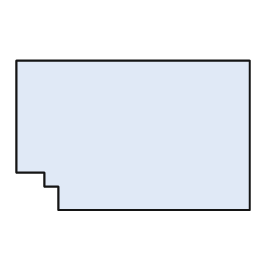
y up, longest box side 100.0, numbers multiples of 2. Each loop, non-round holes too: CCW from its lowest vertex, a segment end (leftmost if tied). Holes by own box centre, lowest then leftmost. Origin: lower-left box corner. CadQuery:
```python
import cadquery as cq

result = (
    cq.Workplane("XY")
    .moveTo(18.0, 0.0)
    .lineTo(100.0, 0.0)
    .lineTo(100.0, 64.0)
    .lineTo(0.0, 64.0)
    .lineTo(0.0, 16.0)
    .lineTo(12.0, 16.0)
    .lineTo(12.0, 10.0)
    .lineTo(18.0, 10.0)
    .close()
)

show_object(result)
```